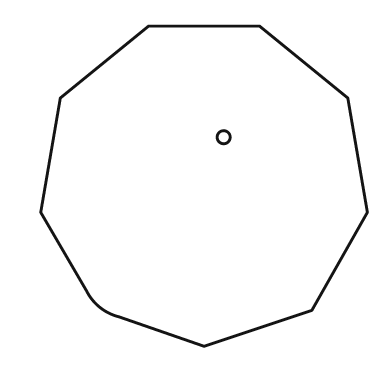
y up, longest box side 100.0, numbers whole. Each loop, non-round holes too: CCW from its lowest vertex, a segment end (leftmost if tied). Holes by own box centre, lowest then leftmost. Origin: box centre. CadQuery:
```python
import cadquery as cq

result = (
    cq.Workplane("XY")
    .moveTo(0.0, -49.0)
    .lineTo(33.0, -38.0)
    .lineTo(50.0, -8.0)
    .lineTo(44.0, 27.0)
    .lineTo(17.0, 49.0)
    .lineTo(-17.0, 49.0)
    .lineTo(-44.0, 27.0)
    .lineTo(-50.0, -8.0)
    .lineTo(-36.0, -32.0)
    .threePointArc((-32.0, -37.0), (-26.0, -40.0))
    .close()
    .moveTo(6.0, 15.0)
    .circle(2.0)
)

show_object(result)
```